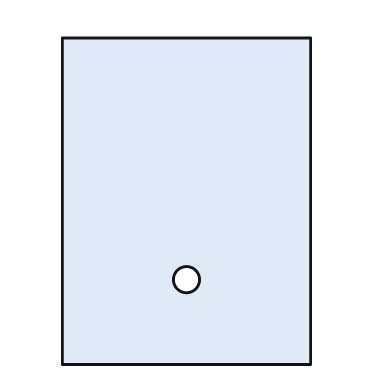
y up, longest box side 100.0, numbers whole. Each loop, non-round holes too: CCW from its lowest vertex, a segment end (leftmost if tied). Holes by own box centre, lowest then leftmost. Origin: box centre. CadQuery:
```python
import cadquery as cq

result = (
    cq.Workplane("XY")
    .moveTo(-38.0, -50.0)
    .lineTo(38.0, -50.0)
    .lineTo(38.0, 50.0)
    .lineTo(-38.0, 50.0)
    .close()
    .moveTo(0.0, -24.0)
    .circle(4.0)
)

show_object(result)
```